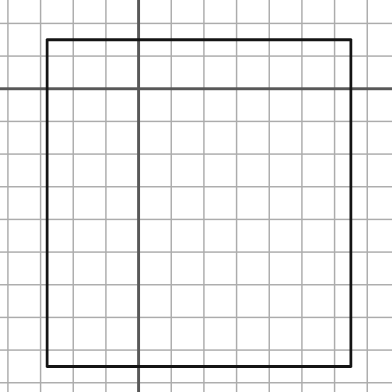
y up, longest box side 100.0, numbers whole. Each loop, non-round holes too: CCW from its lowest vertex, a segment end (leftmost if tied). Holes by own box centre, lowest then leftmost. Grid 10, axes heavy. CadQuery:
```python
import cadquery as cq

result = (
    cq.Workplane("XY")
    .moveTo(-28.0, -85.0)
    .lineTo(65.0, -85.0)
    .lineTo(65.0, 15.0)
    .lineTo(-28.0, 15.0)
    .close()
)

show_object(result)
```